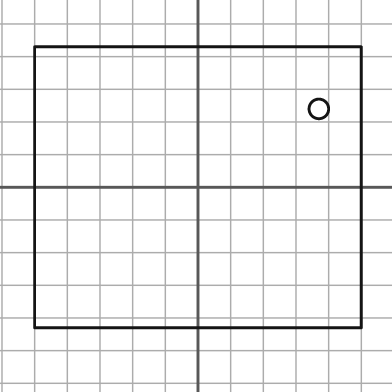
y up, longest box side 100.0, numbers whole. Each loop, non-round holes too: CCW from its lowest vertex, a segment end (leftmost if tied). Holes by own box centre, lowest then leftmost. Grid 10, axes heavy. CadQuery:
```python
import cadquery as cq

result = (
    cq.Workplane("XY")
    .moveTo(-50.0, -43.0)
    .lineTo(50.0, -43.0)
    .lineTo(50.0, 43.0)
    .lineTo(-50.0, 43.0)
    .close()
    .moveTo(37.0, 24.0)
    .circle(3.0)
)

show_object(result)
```